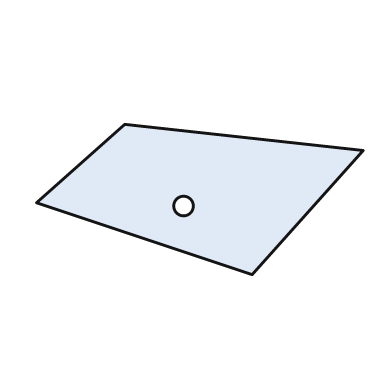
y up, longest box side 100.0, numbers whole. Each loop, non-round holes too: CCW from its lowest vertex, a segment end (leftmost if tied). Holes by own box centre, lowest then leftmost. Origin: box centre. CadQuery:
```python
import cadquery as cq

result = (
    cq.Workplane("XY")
    .moveTo(16.0, -23.0)
    .lineTo(50.0, 15.0)
    .lineTo(-23.0, 23.0)
    .lineTo(-50.0, -1.0)
    .close()
    .moveTo(-5.0, -2.0)
    .circle(3.0)
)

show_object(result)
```